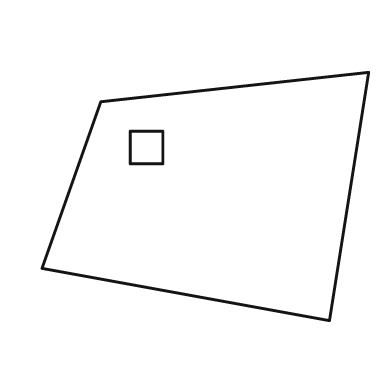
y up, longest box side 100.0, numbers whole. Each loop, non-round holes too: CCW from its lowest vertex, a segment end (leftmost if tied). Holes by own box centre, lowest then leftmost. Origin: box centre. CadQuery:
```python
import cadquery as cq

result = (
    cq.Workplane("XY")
    .moveTo(38.0, -38.0)
    .lineTo(50.0, 38.0)
    .lineTo(-32.0, 29.0)
    .lineTo(-50.0, -22.0)
    .close()
    .moveTo(-23.0, 10.0)
    .lineTo(-13.0, 10.0)
    .lineTo(-13.0, 20.0)
    .lineTo(-23.0, 20.0)
    .close()
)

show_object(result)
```